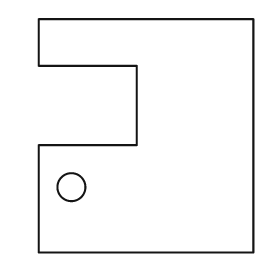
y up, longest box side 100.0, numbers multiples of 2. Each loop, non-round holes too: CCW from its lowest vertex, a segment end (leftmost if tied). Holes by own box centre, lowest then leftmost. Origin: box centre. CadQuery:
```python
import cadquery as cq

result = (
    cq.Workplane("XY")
    .moveTo(-46.0, -50.0)
    .lineTo(46.0, -50.0)
    .lineTo(46.0, 50.0)
    .lineTo(-46.0, 50.0)
    .lineTo(-46.0, 30.0)
    .lineTo(-4.0, 30.0)
    .lineTo(-4.0, -4.0)
    .lineTo(-46.0, -4.0)
    .close()
    .moveTo(-32.0, -22.0)
    .circle(6.0)
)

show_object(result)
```